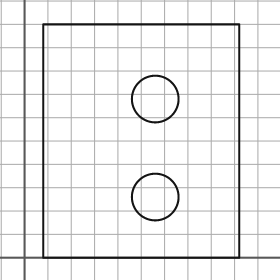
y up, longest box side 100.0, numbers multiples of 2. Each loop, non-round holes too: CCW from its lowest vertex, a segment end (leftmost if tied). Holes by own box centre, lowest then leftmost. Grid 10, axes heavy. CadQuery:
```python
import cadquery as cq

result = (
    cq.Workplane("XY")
    .moveTo(8.0, 0.0)
    .lineTo(92.0, 0.0)
    .lineTo(92.0, 100.0)
    .lineTo(8.0, 100.0)
    .close()
    .moveTo(56.0, 26.0)
    .circle(10.0)
    .moveTo(56.0, 68.0)
    .circle(10.0)
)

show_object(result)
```